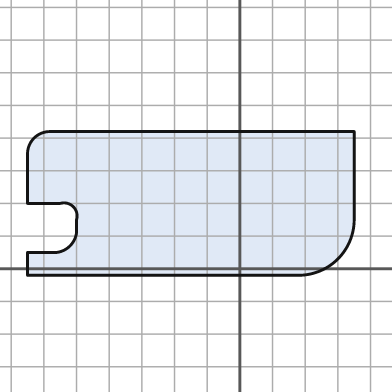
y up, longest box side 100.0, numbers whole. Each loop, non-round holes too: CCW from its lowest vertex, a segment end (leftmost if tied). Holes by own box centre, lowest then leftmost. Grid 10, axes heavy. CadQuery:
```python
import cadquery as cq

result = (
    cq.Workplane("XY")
    .moveTo(-65.0, -2.0)
    .lineTo(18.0, -2.0)
    .threePointArc((30.0, 3.0), (35.0, 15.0))
    .lineTo(35.0, 42.0)
    .lineTo(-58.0, 42.0)
    .threePointArc((-63.0, 40.0), (-65.0, 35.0))
    .lineTo(-65.0, 20.0)
    .lineTo(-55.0, 20.0)
    .threePointArc((-51.0, 19.0), (-50.0, 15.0))
    .lineTo(-50.0, 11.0)
    .threePointArc((-52.0, 7.0), (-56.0, 5.0))
    .lineTo(-65.0, 5.0)
    .close()
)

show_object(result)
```